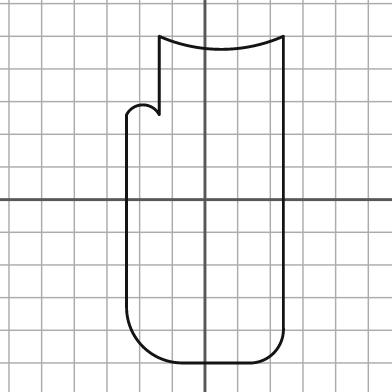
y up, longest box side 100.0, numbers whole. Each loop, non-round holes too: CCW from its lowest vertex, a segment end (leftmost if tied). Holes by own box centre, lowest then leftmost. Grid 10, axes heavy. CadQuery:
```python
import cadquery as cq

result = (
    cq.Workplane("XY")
    .moveTo(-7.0, -50.0)
    .lineTo(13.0, -50.0)
    .threePointArc((21.0, -47.0), (24.0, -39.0))
    .lineTo(24.0, 50.0)
    .threePointArc((5.0, 46.0), (-14.0, 50.0))
    .lineTo(-14.0, 26.0)
    .threePointArc((-19.0, 29.0), (-24.0, 26.0))
    .lineTo(-24.0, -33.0)
    .threePointArc((-19.0, -45.0), (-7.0, -50.0))
    .close()
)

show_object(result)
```